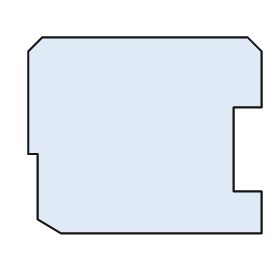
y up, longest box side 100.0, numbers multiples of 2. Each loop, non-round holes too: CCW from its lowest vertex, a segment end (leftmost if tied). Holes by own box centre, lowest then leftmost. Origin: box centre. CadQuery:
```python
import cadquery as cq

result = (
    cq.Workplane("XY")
    .moveTo(-36.0, -42.0)
    .lineTo(50.0, -42.0)
    .lineTo(50.0, -24.0)
    .lineTo(38.0, -24.0)
    .lineTo(38.0, 12.0)
    .lineTo(50.0, 12.0)
    .lineTo(50.0, 36.0)
    .lineTo(44.0, 42.0)
    .lineTo(-44.0, 42.0)
    .lineTo(-50.0, 36.0)
    .lineTo(-50.0, -8.0)
    .lineTo(-46.0, -8.0)
    .lineTo(-46.0, -36.0)
    .close()
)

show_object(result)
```